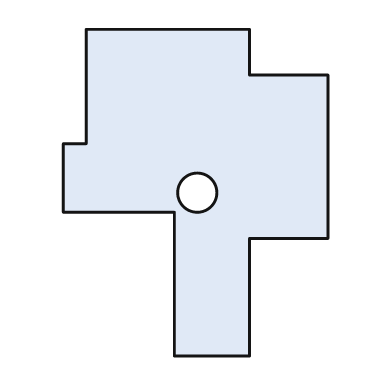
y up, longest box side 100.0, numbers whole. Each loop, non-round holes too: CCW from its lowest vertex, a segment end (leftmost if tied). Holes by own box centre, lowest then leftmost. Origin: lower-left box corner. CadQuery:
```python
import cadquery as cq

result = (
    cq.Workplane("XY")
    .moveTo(34.0, 0.0)
    .lineTo(57.0, 0.0)
    .lineTo(57.0, 36.0)
    .lineTo(81.0, 36.0)
    .lineTo(81.0, 86.0)
    .lineTo(57.0, 86.0)
    .lineTo(57.0, 100.0)
    .lineTo(7.0, 100.0)
    .lineTo(7.0, 65.0)
    .lineTo(0.0, 65.0)
    .lineTo(0.0, 44.0)
    .lineTo(34.0, 44.0)
    .close()
    .moveTo(41.0, 50.0)
    .circle(6.0)
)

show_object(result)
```